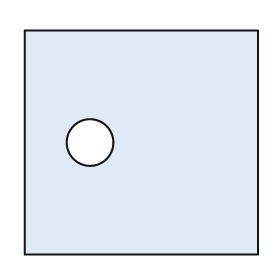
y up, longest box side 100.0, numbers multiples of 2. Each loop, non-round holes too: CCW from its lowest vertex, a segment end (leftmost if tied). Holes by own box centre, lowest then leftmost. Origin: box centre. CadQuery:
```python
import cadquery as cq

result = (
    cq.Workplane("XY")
    .moveTo(-50.0, -48.0)
    .lineTo(50.0, -48.0)
    .lineTo(50.0, 48.0)
    .lineTo(-50.0, 48.0)
    .close()
    .moveTo(-22.0, 0.0)
    .circle(10.0)
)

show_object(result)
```